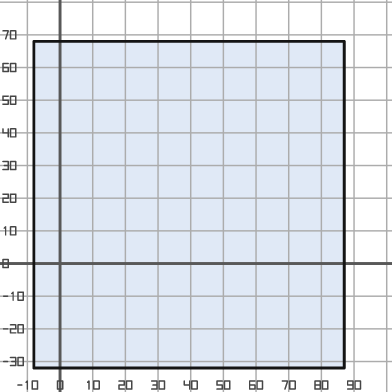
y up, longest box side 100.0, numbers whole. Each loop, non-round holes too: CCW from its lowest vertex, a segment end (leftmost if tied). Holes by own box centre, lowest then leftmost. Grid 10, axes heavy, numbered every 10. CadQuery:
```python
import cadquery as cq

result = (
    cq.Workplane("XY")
    .moveTo(-8.0, -32.0)
    .lineTo(87.0, -32.0)
    .lineTo(87.0, 68.0)
    .lineTo(-8.0, 68.0)
    .close()
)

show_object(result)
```